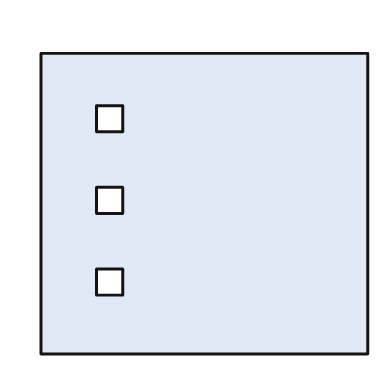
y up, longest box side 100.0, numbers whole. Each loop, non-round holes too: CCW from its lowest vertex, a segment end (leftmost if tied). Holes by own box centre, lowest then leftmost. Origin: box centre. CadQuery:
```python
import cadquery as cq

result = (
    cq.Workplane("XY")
    .moveTo(-50.0, -46.0)
    .lineTo(50.0, -46.0)
    .lineTo(50.0, 46.0)
    .lineTo(-50.0, 46.0)
    .close()
    .moveTo(-33.0, -28.0)
    .lineTo(-25.0, -28.0)
    .lineTo(-25.0, -20.0)
    .lineTo(-33.0, -20.0)
    .close()
    .moveTo(-33.0, -3.0)
    .lineTo(-25.0, -3.0)
    .lineTo(-25.0, 5.0)
    .lineTo(-33.0, 5.0)
    .close()
    .moveTo(-33.0, 22.0)
    .lineTo(-25.0, 22.0)
    .lineTo(-25.0, 30.0)
    .lineTo(-33.0, 30.0)
    .close()
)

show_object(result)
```